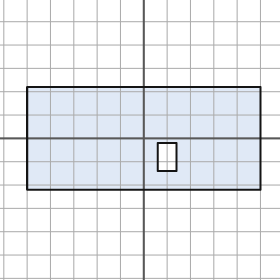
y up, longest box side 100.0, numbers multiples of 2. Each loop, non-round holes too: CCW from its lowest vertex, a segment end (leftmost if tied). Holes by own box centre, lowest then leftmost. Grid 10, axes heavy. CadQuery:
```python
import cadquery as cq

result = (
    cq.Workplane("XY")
    .moveTo(-50.0, -22.0)
    .lineTo(50.0, -22.0)
    .lineTo(50.0, 22.0)
    .lineTo(-50.0, 22.0)
    .close()
    .moveTo(6.0, -14.0)
    .lineTo(14.0, -14.0)
    .lineTo(14.0, -2.0)
    .lineTo(6.0, -2.0)
    .close()
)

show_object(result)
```